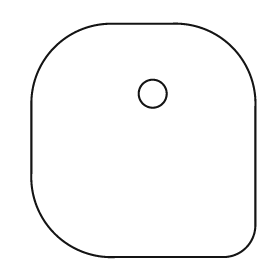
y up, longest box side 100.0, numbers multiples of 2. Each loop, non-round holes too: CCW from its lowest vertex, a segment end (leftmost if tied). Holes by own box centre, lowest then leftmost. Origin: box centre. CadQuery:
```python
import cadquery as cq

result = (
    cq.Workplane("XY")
    .moveTo(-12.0, -50.0)
    .lineTo(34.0, -50.0)
    .threePointArc((44.0, -46.0), (48.0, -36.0))
    .lineTo(48.0, 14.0)
    .threePointArc((38.0, 40.0), (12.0, 50.0))
    .lineTo(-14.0, 50.0)
    .threePointArc((-38.0, 40.0), (-48.0, 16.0))
    .lineTo(-48.0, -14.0)
    .threePointArc((-38.0, -40.0), (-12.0, -50.0))
    .close()
    .moveTo(4.0, 20.0)
    .circle(6.0)
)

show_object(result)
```